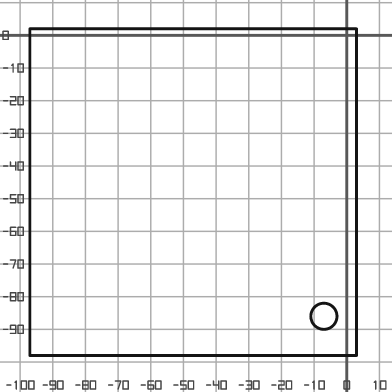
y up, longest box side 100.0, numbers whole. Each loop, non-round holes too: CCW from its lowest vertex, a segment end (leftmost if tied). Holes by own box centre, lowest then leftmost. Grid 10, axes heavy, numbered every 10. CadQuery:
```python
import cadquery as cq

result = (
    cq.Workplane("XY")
    .moveTo(-97.0, -98.0)
    .lineTo(3.0, -98.0)
    .lineTo(3.0, 2.0)
    .lineTo(-97.0, 2.0)
    .close()
    .moveTo(-7.0, -86.0)
    .circle(4.0)
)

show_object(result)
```